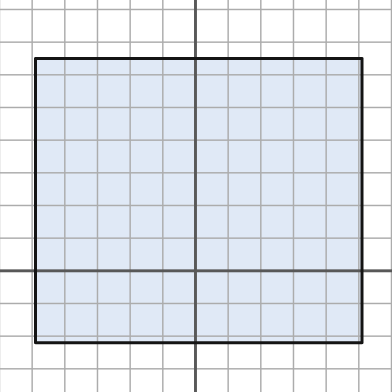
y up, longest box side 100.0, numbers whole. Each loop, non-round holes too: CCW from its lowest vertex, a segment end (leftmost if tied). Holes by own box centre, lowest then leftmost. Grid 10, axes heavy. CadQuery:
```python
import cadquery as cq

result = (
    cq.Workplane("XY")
    .moveTo(-49.0, -22.0)
    .lineTo(51.0, -22.0)
    .lineTo(51.0, 65.0)
    .lineTo(-49.0, 65.0)
    .close()
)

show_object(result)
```